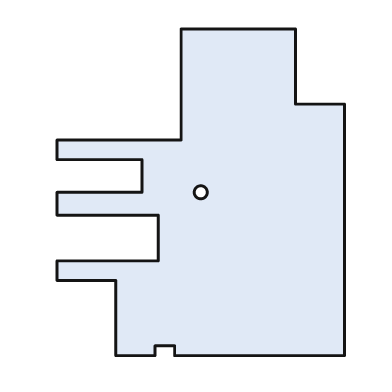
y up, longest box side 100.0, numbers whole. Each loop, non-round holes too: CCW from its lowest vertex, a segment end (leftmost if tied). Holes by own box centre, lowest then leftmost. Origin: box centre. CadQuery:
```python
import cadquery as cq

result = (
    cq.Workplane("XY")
    .moveTo(-26.0, -50.0)
    .lineTo(-14.0, -50.0)
    .lineTo(-14.0, -47.0)
    .lineTo(-8.0, -47.0)
    .lineTo(-8.0, -50.0)
    .lineTo(44.0, -50.0)
    .lineTo(44.0, 27.0)
    .lineTo(29.0, 27.0)
    .lineTo(29.0, 50.0)
    .lineTo(-6.0, 50.0)
    .lineTo(-6.0, 16.0)
    .lineTo(-44.0, 16.0)
    .lineTo(-44.0, 10.0)
    .lineTo(-18.0, 10.0)
    .lineTo(-18.0, 0.0)
    .lineTo(-44.0, 0.0)
    .lineTo(-44.0, -7.0)
    .lineTo(-13.0, -7.0)
    .lineTo(-13.0, -21.0)
    .lineTo(-44.0, -21.0)
    .lineTo(-44.0, -27.0)
    .lineTo(-26.0, -27.0)
    .close()
    .moveTo(0.0, 0.0)
    .circle(2.0)
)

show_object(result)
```